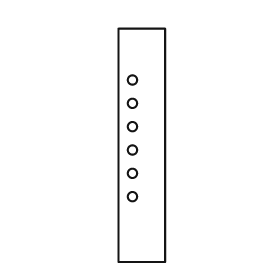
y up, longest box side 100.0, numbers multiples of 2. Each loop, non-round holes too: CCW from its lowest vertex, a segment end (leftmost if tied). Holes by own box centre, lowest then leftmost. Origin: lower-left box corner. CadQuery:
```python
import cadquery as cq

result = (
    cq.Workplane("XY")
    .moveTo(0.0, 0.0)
    .lineTo(20.0, 0.0)
    .lineTo(20.0, 100.0)
    .lineTo(0.0, 100.0)
    .close()
    .moveTo(6.0, 28.0)
    .circle(2.0)
    .moveTo(6.0, 38.0)
    .circle(2.0)
    .moveTo(6.0, 48.0)
    .circle(2.0)
    .moveTo(6.0, 58.0)
    .circle(2.0)
    .moveTo(6.0, 68.0)
    .circle(2.0)
    .moveTo(6.0, 78.0)
    .circle(2.0)
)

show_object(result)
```